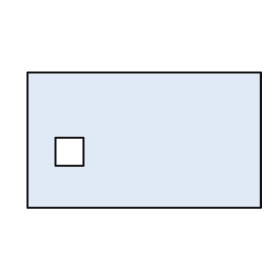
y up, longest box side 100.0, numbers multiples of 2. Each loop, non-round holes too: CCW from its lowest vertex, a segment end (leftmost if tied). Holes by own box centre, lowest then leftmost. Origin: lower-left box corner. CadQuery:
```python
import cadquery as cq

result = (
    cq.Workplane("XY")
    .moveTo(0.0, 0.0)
    .lineTo(100.0, 0.0)
    .lineTo(100.0, 58.0)
    .lineTo(0.0, 58.0)
    .close()
    .moveTo(12.0, 18.0)
    .lineTo(24.0, 18.0)
    .lineTo(24.0, 30.0)
    .lineTo(12.0, 30.0)
    .close()
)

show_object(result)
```